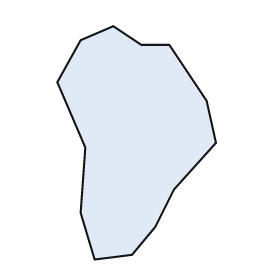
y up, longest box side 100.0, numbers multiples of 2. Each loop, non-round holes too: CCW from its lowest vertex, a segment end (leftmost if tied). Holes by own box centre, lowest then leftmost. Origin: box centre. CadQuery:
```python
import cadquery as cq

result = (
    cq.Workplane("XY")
    .moveTo(-18.0, -50.0)
    .lineTo(-2.0, -48.0)
    .lineTo(8.0, -36.0)
    .lineTo(16.0, -20.0)
    .lineTo(34.0, 0.0)
    .lineTo(30.0, 18.0)
    .lineTo(14.0, 42.0)
    .lineTo(2.0, 42.0)
    .lineTo(-10.0, 50.0)
    .lineTo(-24.0, 44.0)
    .lineTo(-34.0, 26.0)
    .lineTo(-22.0, -2.0)
    .lineTo(-24.0, -30.0)
    .close()
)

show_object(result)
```